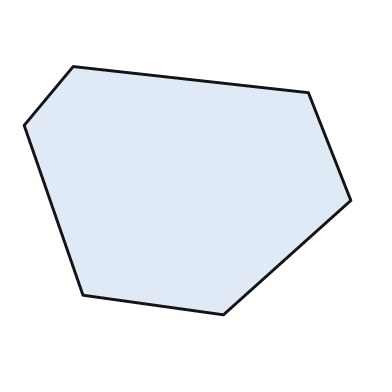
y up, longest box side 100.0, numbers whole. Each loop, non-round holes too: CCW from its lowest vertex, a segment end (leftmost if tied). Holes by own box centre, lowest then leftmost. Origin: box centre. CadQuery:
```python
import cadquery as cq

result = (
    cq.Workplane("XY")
    .moveTo(11.0, -38.0)
    .lineTo(50.0, -3.0)
    .lineTo(37.0, 30.0)
    .lineTo(-35.0, 38.0)
    .lineTo(-50.0, 20.0)
    .lineTo(-32.0, -32.0)
    .close()
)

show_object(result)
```